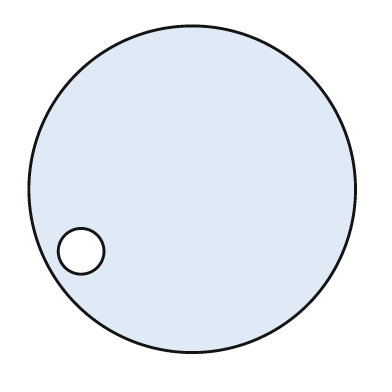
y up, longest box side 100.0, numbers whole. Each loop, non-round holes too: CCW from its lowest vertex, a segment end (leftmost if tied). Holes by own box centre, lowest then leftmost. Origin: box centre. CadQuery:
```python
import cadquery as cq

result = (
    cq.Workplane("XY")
    .moveTo(0.0, 0.0)
    .circle(50.0)
    .moveTo(-34.0, -19.0)
    .circle(7.0)
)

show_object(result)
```